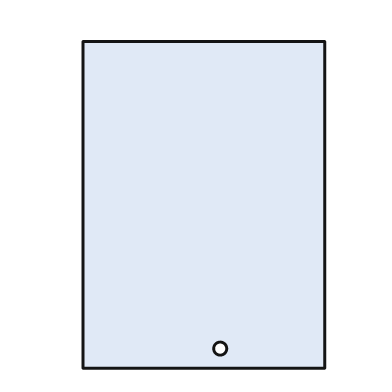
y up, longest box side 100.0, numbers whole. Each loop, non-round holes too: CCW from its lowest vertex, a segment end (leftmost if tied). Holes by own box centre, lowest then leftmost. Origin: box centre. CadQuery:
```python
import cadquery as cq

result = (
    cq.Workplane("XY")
    .moveTo(-37.0, -50.0)
    .lineTo(37.0, -50.0)
    .lineTo(37.0, 50.0)
    .lineTo(-37.0, 50.0)
    .close()
    .moveTo(5.0, -44.0)
    .circle(2.0)
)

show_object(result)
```